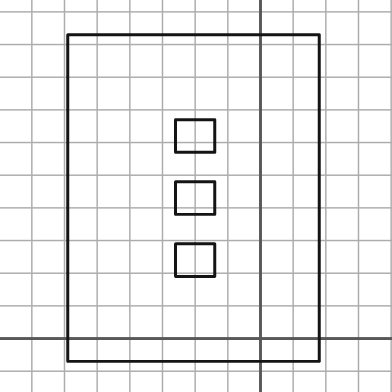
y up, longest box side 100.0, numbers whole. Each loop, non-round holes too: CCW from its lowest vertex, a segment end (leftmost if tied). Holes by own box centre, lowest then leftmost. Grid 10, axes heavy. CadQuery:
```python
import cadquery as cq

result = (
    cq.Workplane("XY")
    .moveTo(-59.0, -7.0)
    .lineTo(18.0, -7.0)
    .lineTo(18.0, 93.0)
    .lineTo(-59.0, 93.0)
    .close()
    .moveTo(-26.0, 19.0)
    .lineTo(-14.0, 19.0)
    .lineTo(-14.0, 29.0)
    .lineTo(-26.0, 29.0)
    .close()
    .moveTo(-26.0, 38.0)
    .lineTo(-14.0, 38.0)
    .lineTo(-14.0, 48.0)
    .lineTo(-26.0, 48.0)
    .close()
    .moveTo(-26.0, 57.0)
    .lineTo(-14.0, 57.0)
    .lineTo(-14.0, 67.0)
    .lineTo(-26.0, 67.0)
    .close()
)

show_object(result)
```